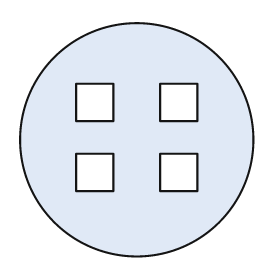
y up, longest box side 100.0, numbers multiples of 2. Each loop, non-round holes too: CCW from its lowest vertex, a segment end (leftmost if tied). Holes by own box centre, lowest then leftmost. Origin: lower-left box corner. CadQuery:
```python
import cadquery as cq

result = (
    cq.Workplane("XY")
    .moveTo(50.0, 50.0)
    .circle(50.0)
    .moveTo(24.0, 28.0)
    .lineTo(40.0, 28.0)
    .lineTo(40.0, 44.0)
    .lineTo(24.0, 44.0)
    .close()
    .moveTo(60.0, 28.0)
    .lineTo(76.0, 28.0)
    .lineTo(76.0, 44.0)
    .lineTo(60.0, 44.0)
    .close()
    .moveTo(24.0, 58.0)
    .lineTo(40.0, 58.0)
    .lineTo(40.0, 74.0)
    .lineTo(24.0, 74.0)
    .close()
    .moveTo(60.0, 58.0)
    .lineTo(76.0, 58.0)
    .lineTo(76.0, 74.0)
    .lineTo(60.0, 74.0)
    .close()
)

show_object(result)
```